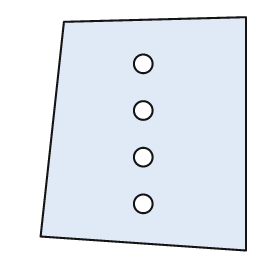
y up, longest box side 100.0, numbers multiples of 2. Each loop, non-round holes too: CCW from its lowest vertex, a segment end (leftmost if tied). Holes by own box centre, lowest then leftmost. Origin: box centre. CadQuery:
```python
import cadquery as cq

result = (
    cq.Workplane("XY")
    .moveTo(44.0, -50.0)
    .lineTo(44.0, 50.0)
    .lineTo(-34.0, 48.0)
    .lineTo(-44.0, -44.0)
    .close()
    .moveTo(0.0, -30.0)
    .circle(4.0)
    .moveTo(0.0, -10.0)
    .circle(4.0)
    .moveTo(0.0, 10.0)
    .circle(4.0)
    .moveTo(0.0, 30.0)
    .circle(4.0)
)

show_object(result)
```